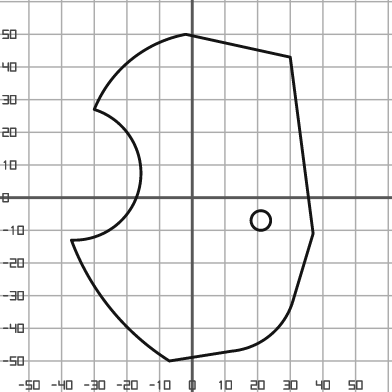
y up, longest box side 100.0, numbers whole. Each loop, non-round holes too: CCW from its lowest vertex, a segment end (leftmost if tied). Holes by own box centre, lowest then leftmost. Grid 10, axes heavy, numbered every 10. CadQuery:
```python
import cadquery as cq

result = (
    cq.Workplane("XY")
    .moveTo(-7.0, -50.0)
    .lineTo(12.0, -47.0)
    .threePointArc((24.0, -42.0), (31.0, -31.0))
    .lineTo(37.0, -11.0)
    .lineTo(30.0, 43.0)
    .lineTo(-2.0, 50.0)
    .threePointArc((-19.0, 42.0), (-30.0, 27.0))
    .threePointArc((-16.0, 4.0), (-37.0, -13.0))
    .threePointArc((-25.0, -34.0), (-7.0, -50.0))
    .close()
    .moveTo(21.0, -7.0)
    .circle(3.0)
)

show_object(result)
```